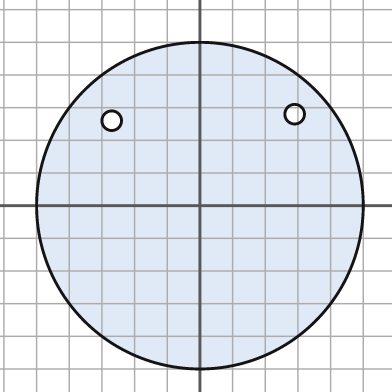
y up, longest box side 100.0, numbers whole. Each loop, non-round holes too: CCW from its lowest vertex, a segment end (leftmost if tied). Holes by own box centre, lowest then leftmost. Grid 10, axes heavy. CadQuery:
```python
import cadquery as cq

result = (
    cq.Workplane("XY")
    .moveTo(0.0, 0.0)
    .circle(50.0)
    .moveTo(-27.0, 26.0)
    .circle(3.0)
    .moveTo(29.0, 28.0)
    .circle(3.0)
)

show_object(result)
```